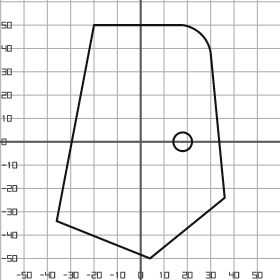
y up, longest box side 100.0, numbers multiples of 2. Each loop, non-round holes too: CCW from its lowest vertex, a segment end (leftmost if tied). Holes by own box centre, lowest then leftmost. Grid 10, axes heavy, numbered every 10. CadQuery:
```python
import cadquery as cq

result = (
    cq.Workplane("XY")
    .moveTo(4.0, -50.0)
    .lineTo(36.0, -24.0)
    .lineTo(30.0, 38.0)
    .threePointArc((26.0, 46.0), (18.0, 50.0))
    .lineTo(-20.0, 50.0)
    .lineTo(-36.0, -34.0)
    .close()
    .moveTo(18.0, 0.0)
    .circle(4.0)
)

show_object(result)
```